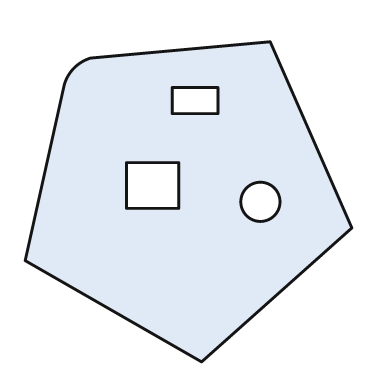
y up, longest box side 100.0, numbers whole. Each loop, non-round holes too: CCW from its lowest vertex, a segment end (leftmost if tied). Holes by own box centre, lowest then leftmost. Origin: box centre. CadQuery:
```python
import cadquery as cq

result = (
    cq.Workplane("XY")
    .moveTo(4.0, -49.0)
    .lineTo(50.0, -8.0)
    .lineTo(25.0, 49.0)
    .lineTo(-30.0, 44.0)
    .threePointArc((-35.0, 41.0), (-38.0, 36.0))
    .lineTo(-50.0, -18.0)
    .close()
    .moveTo(22.0, 0.0)
    .circle(6.0)
    .moveTo(-19.0, -2.0)
    .lineTo(-3.0, -2.0)
    .lineTo(-3.0, 12.0)
    .lineTo(-19.0, 12.0)
    .close()
    .moveTo(-5.0, 27.0)
    .lineTo(9.0, 27.0)
    .lineTo(9.0, 35.0)
    .lineTo(-5.0, 35.0)
    .close()
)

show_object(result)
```